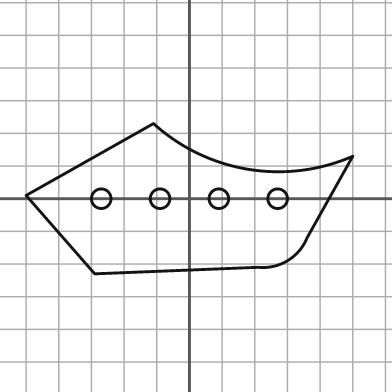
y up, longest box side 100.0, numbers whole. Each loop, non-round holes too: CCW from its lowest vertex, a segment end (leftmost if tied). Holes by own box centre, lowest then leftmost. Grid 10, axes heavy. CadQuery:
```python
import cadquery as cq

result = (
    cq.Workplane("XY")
    .moveTo(-29.0, -23.0)
    .lineTo(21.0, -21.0)
    .threePointArc((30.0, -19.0), (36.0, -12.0))
    .lineTo(50.0, 13.0)
    .threePointArc((18.0, 9.0), (-11.0, 23.0))
    .lineTo(-50.0, 1.0)
    .close()
    .moveTo(-27.0, 0.0)
    .circle(3.0)
    .moveTo(-9.0, 0.0)
    .circle(3.0)
    .moveTo(9.0, 0.0)
    .circle(3.0)
    .moveTo(27.0, 0.0)
    .circle(3.0)
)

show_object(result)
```